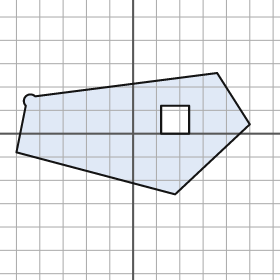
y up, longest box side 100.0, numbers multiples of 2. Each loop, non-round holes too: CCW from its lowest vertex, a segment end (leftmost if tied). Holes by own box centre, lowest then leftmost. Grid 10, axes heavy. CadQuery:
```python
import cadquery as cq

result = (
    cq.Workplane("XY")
    .moveTo(18.0, -26.0)
    .lineTo(50.0, 4.0)
    .lineTo(36.0, 26.0)
    .lineTo(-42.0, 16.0)
    .threePointArc((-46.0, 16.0), (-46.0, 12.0))
    .lineTo(-50.0, -8.0)
    .close()
    .moveTo(12.0, 0.0)
    .lineTo(24.0, 0.0)
    .lineTo(24.0, 12.0)
    .lineTo(12.0, 12.0)
    .close()
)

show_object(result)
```